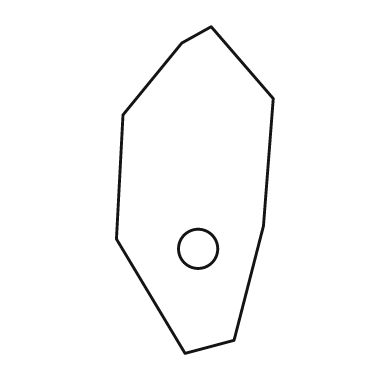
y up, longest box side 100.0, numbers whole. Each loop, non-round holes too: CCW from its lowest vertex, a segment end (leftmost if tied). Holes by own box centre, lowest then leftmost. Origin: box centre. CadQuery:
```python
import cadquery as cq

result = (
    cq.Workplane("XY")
    .moveTo(-3.0, -50.0)
    .lineTo(12.0, -46.0)
    .lineTo(21.0, -11.0)
    .lineTo(24.0, 28.0)
    .lineTo(5.0, 50.0)
    .lineTo(-4.0, 45.0)
    .lineTo(-22.0, 23.0)
    .lineTo(-24.0, -15.0)
    .close()
    .moveTo(1.0, -18.0)
    .circle(6.0)
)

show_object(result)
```